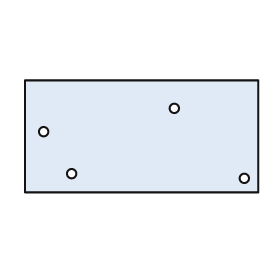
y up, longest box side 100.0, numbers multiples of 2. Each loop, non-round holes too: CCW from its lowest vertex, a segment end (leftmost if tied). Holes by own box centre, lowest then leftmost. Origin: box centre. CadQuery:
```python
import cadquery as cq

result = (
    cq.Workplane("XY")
    .moveTo(-50.0, -24.0)
    .lineTo(50.0, -24.0)
    .lineTo(50.0, 24.0)
    .lineTo(-50.0, 24.0)
    .close()
    .moveTo(44.0, -18.0)
    .circle(2.0)
    .moveTo(-30.0, -16.0)
    .circle(2.0)
    .moveTo(-42.0, 2.0)
    .circle(2.0)
    .moveTo(14.0, 12.0)
    .circle(2.0)
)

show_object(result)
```